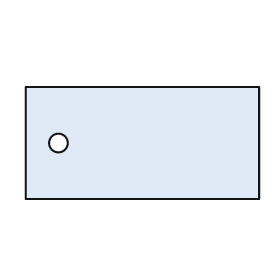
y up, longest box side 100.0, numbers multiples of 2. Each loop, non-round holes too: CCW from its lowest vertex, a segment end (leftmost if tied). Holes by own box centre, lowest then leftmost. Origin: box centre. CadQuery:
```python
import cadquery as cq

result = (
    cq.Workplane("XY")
    .moveTo(-50.0, -24.0)
    .lineTo(50.0, -24.0)
    .lineTo(50.0, 24.0)
    .lineTo(-50.0, 24.0)
    .close()
    .moveTo(-36.0, 0.0)
    .circle(4.0)
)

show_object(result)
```